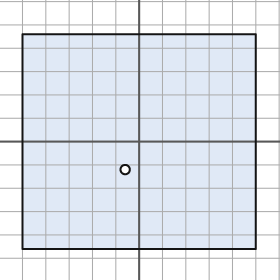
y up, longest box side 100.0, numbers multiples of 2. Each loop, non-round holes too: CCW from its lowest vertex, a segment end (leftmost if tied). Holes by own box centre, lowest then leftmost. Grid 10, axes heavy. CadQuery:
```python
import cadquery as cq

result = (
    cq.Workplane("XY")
    .moveTo(-50.0, -46.0)
    .lineTo(50.0, -46.0)
    .lineTo(50.0, 46.0)
    .lineTo(-50.0, 46.0)
    .close()
    .moveTo(-6.0, -12.0)
    .circle(2.0)
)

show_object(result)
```